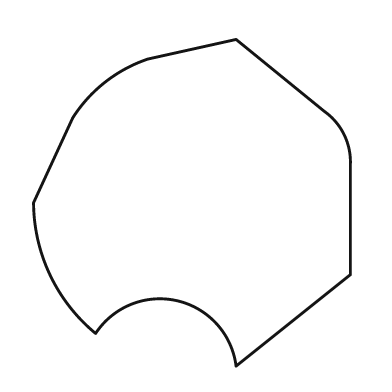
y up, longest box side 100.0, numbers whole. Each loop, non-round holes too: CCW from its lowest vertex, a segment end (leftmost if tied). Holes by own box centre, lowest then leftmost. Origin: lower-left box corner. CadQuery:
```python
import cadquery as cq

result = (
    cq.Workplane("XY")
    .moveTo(62.0, 0.0)
    .lineTo(97.0, 28.0)
    .lineTo(97.0, 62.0)
    .threePointArc((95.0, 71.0), (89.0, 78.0))
    .lineTo(62.0, 100.0)
    .lineTo(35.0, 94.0)
    .threePointArc((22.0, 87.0), (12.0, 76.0))
    .lineTo(0.0, 50.0)
    .threePointArc((5.0, 28.0), (19.0, 10.0))
    .threePointArc((44.0, 20.0), (62.0, 0.0))
    .close()
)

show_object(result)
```